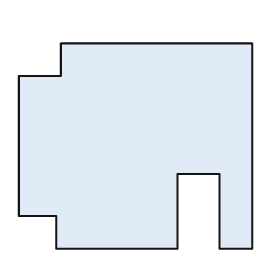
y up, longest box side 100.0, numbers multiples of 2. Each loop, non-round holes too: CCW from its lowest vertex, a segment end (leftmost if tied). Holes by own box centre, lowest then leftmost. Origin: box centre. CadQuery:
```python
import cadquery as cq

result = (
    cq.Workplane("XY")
    .moveTo(-34.0, -44.0)
    .lineTo(18.0, -44.0)
    .lineTo(18.0, -12.0)
    .lineTo(36.0, -12.0)
    .lineTo(36.0, -44.0)
    .lineTo(50.0, -44.0)
    .lineTo(50.0, 44.0)
    .lineTo(-32.0, 44.0)
    .lineTo(-32.0, 30.0)
    .lineTo(-50.0, 30.0)
    .lineTo(-50.0, -30.0)
    .lineTo(-34.0, -30.0)
    .close()
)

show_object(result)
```